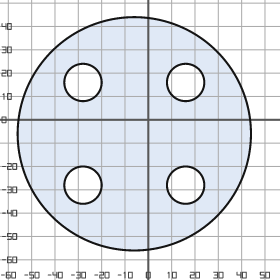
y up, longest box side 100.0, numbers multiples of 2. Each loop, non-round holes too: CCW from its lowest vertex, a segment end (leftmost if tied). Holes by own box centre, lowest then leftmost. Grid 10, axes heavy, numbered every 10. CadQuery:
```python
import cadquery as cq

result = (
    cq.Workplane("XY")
    .moveTo(-6.0, -6.0)
    .circle(50.0)
    .moveTo(-28.0, -28.0)
    .circle(8.0)
    .moveTo(16.0, -28.0)
    .circle(8.0)
    .moveTo(-28.0, 16.0)
    .circle(8.0)
    .moveTo(16.0, 16.0)
    .circle(8.0)
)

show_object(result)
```